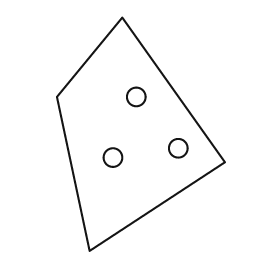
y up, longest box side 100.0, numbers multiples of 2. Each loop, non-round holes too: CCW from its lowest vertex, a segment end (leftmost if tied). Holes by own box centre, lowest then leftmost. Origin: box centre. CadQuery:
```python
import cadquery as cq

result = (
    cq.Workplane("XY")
    .moveTo(-22.0, -50.0)
    .lineTo(36.0, -12.0)
    .lineTo(-8.0, 50.0)
    .lineTo(-36.0, 16.0)
    .close()
    .moveTo(-12.0, -10.0)
    .circle(4.0)
    .moveTo(16.0, -6.0)
    .circle(4.0)
    .moveTo(-2.0, 16.0)
    .circle(4.0)
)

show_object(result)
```